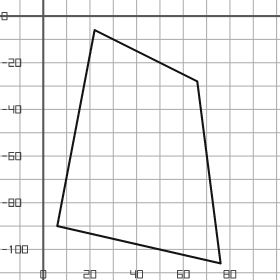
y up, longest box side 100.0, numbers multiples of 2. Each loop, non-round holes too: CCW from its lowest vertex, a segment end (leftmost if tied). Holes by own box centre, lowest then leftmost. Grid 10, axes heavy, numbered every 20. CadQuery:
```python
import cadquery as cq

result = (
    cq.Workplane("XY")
    .moveTo(76.0, -106.0)
    .lineTo(66.0, -28.0)
    .lineTo(22.0, -6.0)
    .lineTo(6.0, -90.0)
    .close()
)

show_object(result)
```